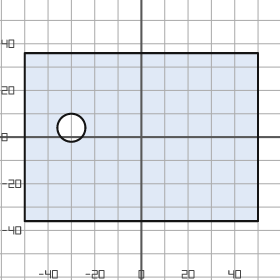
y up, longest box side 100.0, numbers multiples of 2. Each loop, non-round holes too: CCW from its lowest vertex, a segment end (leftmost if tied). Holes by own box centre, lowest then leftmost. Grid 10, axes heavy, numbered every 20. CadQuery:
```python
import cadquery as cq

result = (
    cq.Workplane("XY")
    .moveTo(-50.0, -36.0)
    .lineTo(50.0, -36.0)
    .lineTo(50.0, 36.0)
    .lineTo(-50.0, 36.0)
    .close()
    .moveTo(-30.0, 4.0)
    .circle(6.0)
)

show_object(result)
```